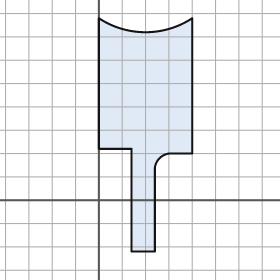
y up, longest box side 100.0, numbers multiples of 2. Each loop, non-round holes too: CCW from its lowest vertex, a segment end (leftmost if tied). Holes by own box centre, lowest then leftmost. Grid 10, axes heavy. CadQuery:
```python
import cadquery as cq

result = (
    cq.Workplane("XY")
    .moveTo(14.0, -22.0)
    .lineTo(24.0, -22.0)
    .lineTo(24.0, 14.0)
    .threePointArc((26.0, 18.0), (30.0, 20.0))
    .lineTo(40.0, 20.0)
    .lineTo(40.0, 78.0)
    .threePointArc((20.0, 72.0), (0.0, 78.0))
    .lineTo(0.0, 22.0)
    .lineTo(14.0, 22.0)
    .close()
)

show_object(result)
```